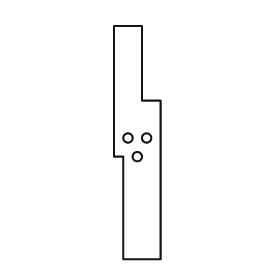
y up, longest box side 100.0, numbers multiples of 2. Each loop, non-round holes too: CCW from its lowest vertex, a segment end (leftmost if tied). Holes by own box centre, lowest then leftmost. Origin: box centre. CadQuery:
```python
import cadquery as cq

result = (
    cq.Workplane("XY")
    .moveTo(-6.0, -50.0)
    .lineTo(10.0, -50.0)
    .lineTo(10.0, 18.0)
    .lineTo(2.0, 18.0)
    .lineTo(2.0, 50.0)
    .lineTo(-10.0, 50.0)
    .lineTo(-10.0, -6.0)
    .lineTo(-6.0, -6.0)
    .close()
    .moveTo(0.0, -6.0)
    .circle(2.0)
    .moveTo(-4.0, 2.0)
    .circle(2.0)
    .moveTo(4.0, 2.0)
    .circle(2.0)
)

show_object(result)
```